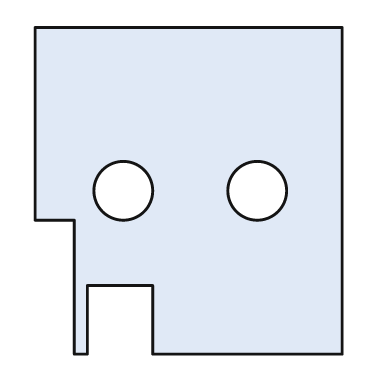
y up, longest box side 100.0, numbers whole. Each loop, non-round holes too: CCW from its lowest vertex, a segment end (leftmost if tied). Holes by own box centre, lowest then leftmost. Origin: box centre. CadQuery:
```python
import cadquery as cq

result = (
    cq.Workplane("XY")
    .moveTo(-35.0, -50.0)
    .lineTo(-31.0, -50.0)
    .lineTo(-31.0, -29.0)
    .lineTo(-11.0, -29.0)
    .lineTo(-11.0, -50.0)
    .lineTo(47.0, -50.0)
    .lineTo(47.0, 50.0)
    .lineTo(-47.0, 50.0)
    .lineTo(-47.0, -9.0)
    .lineTo(-35.0, -9.0)
    .close()
    .moveTo(-20.0, 0.0)
    .circle(9.0)
    .moveTo(21.0, 0.0)
    .circle(9.0)
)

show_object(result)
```